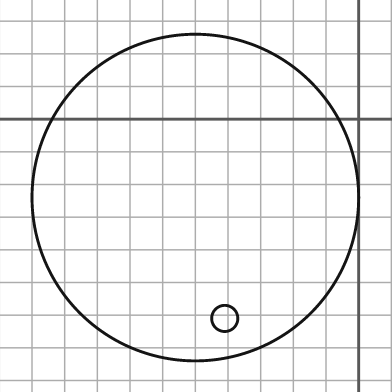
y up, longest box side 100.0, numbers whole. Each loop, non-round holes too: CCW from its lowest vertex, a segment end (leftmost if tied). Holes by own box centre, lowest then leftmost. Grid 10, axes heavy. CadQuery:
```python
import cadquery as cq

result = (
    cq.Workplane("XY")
    .moveTo(-50.0, -24.0)
    .circle(50.0)
    .moveTo(-41.0, -61.0)
    .circle(4.0)
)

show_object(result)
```